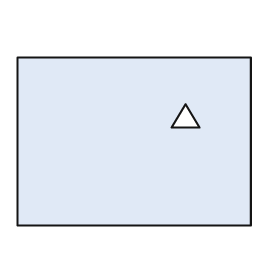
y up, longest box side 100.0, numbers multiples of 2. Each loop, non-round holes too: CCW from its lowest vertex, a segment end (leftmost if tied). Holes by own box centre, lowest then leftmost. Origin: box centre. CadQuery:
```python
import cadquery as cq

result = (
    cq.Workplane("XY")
    .moveTo(-50.0, -36.0)
    .lineTo(50.0, -36.0)
    .lineTo(50.0, 36.0)
    .lineTo(-50.0, 36.0)
    .close()
    .moveTo(16.0, 6.0)
    .lineTo(28.0, 6.0)
    .lineTo(22.0, 16.0)
    .close()
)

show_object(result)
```